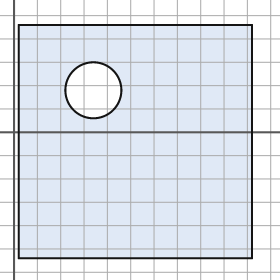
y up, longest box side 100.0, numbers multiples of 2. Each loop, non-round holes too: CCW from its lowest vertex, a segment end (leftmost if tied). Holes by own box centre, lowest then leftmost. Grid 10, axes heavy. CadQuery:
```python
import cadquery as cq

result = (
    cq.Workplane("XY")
    .moveTo(2.0, -54.0)
    .lineTo(102.0, -54.0)
    .lineTo(102.0, 46.0)
    .lineTo(2.0, 46.0)
    .close()
    .moveTo(34.0, 18.0)
    .circle(12.0)
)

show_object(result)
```